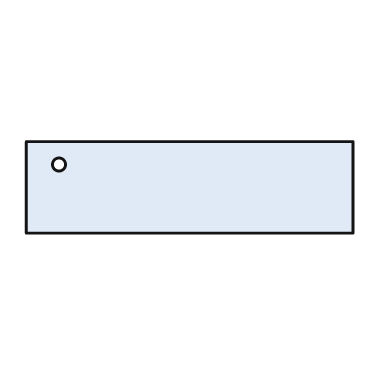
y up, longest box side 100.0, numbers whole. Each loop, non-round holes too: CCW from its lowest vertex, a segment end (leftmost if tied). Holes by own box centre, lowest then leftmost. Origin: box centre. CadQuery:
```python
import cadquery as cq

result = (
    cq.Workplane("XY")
    .moveTo(-50.0, -14.0)
    .lineTo(50.0, -14.0)
    .lineTo(50.0, 14.0)
    .lineTo(-50.0, 14.0)
    .close()
    .moveTo(-40.0, 7.0)
    .circle(2.0)
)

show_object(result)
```